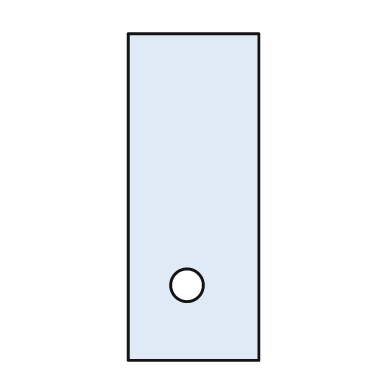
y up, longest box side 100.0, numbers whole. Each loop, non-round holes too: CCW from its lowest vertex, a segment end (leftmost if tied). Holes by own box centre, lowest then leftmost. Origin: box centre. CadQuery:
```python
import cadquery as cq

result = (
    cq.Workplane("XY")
    .moveTo(-20.0, -50.0)
    .lineTo(20.0, -50.0)
    .lineTo(20.0, 50.0)
    .lineTo(-20.0, 50.0)
    .close()
    .moveTo(-2.0, -27.0)
    .circle(5.0)
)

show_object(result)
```